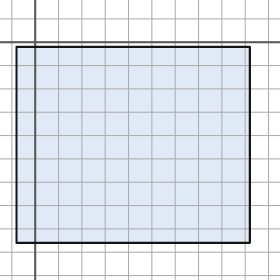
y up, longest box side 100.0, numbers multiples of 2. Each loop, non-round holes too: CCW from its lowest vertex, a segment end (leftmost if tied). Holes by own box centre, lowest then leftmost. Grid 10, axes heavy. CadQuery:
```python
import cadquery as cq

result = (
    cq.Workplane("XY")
    .moveTo(-8.0, -86.0)
    .lineTo(92.0, -86.0)
    .lineTo(92.0, -2.0)
    .lineTo(-8.0, -2.0)
    .close()
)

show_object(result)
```